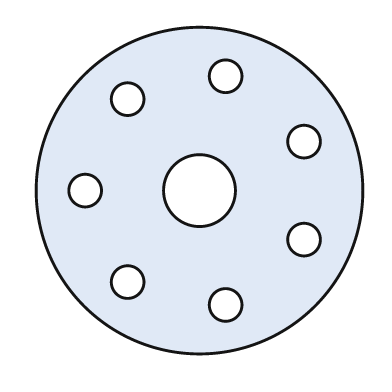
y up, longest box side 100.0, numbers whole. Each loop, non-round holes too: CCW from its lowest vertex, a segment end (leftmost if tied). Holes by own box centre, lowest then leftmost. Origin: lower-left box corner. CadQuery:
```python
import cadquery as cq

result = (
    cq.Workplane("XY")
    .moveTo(50.0, 50.0)
    .circle(50.0)
    .moveTo(58.0, 15.0)
    .circle(5.0)
    .moveTo(28.0, 22.0)
    .circle(5.0)
    .moveTo(82.0, 35.0)
    .circle(5.0)
    .moveTo(15.0, 50.0)
    .circle(5.0)
    .moveTo(50.0, 50.0)
    .circle(11.0)
    .moveTo(82.0, 65.0)
    .circle(5.0)
    .moveTo(28.0, 78.0)
    .circle(5.0)
    .moveTo(58.0, 85.0)
    .circle(5.0)
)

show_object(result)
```